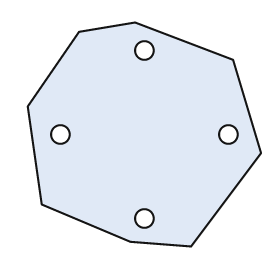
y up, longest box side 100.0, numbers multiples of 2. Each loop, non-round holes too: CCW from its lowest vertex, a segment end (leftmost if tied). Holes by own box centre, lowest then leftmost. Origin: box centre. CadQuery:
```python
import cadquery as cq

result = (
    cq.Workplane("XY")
    .moveTo(20.0, -48.0)
    .lineTo(50.0, -8.0)
    .lineTo(38.0, 32.0)
    .lineTo(-4.0, 48.0)
    .lineTo(-28.0, 44.0)
    .lineTo(-50.0, 12.0)
    .lineTo(-44.0, -30.0)
    .lineTo(-6.0, -46.0)
    .close()
    .moveTo(0.0, -36.0)
    .circle(4.0)
    .moveTo(-36.0, 0.0)
    .circle(4.0)
    .moveTo(36.0, 0.0)
    .circle(4.0)
    .moveTo(0.0, 36.0)
    .circle(4.0)
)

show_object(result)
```